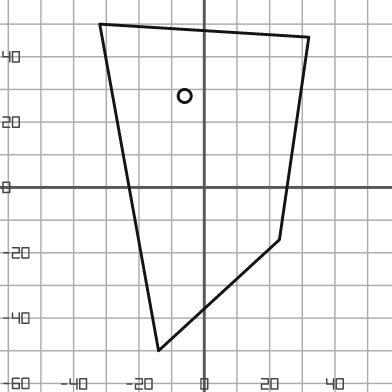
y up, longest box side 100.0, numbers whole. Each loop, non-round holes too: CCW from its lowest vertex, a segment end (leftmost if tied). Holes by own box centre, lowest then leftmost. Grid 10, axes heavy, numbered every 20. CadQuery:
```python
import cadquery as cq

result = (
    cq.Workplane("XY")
    .moveTo(-14.0, -50.0)
    .lineTo(23.0, -16.0)
    .lineTo(32.0, 46.0)
    .lineTo(-32.0, 50.0)
    .close()
    .moveTo(-6.0, 28.0)
    .circle(2.0)
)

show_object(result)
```